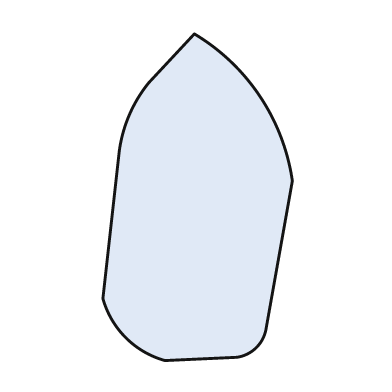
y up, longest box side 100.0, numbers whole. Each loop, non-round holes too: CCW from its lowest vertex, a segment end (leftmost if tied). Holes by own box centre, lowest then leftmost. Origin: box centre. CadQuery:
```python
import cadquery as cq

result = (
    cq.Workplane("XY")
    .moveTo(-10.0, -50.0)
    .lineTo(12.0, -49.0)
    .threePointArc((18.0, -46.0), (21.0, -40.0))
    .lineTo(29.0, 5.0)
    .threePointArc((19.0, 31.0), (-1.0, 50.0))
    .lineTo(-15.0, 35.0)
    .threePointArc((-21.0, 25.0), (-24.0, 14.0))
    .lineTo(-29.0, -31.0)
    .threePointArc((-22.0, -43.0), (-10.0, -50.0))
    .close()
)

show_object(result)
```